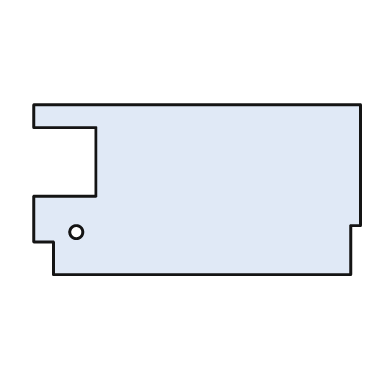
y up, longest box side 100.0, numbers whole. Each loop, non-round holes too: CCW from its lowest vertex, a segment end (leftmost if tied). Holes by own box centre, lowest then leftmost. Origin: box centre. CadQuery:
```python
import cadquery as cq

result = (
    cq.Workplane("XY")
    .moveTo(-44.0, -26.0)
    .lineTo(47.0, -26.0)
    .lineTo(47.0, -11.0)
    .lineTo(50.0, -11.0)
    .lineTo(50.0, 26.0)
    .lineTo(-50.0, 26.0)
    .lineTo(-50.0, 19.0)
    .lineTo(-31.0, 19.0)
    .lineTo(-31.0, -2.0)
    .lineTo(-50.0, -2.0)
    .lineTo(-50.0, -16.0)
    .lineTo(-44.0, -16.0)
    .close()
    .moveTo(-37.0, -13.0)
    .circle(2.0)
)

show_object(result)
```